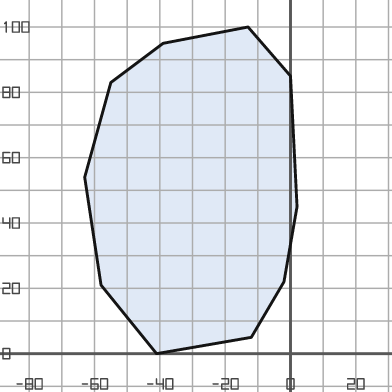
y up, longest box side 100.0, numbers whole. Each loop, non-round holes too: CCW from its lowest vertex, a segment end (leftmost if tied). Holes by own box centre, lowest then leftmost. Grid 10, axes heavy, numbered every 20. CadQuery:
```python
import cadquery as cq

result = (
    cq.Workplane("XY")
    .moveTo(-41.0, 0.0)
    .lineTo(-12.0, 5.0)
    .lineTo(-2.0, 22.0)
    .lineTo(2.0, 45.0)
    .lineTo(0.0, 85.0)
    .lineTo(-13.0, 100.0)
    .lineTo(-39.0, 95.0)
    .lineTo(-55.0, 83.0)
    .lineTo(-63.0, 54.0)
    .lineTo(-58.0, 21.0)
    .close()
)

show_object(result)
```